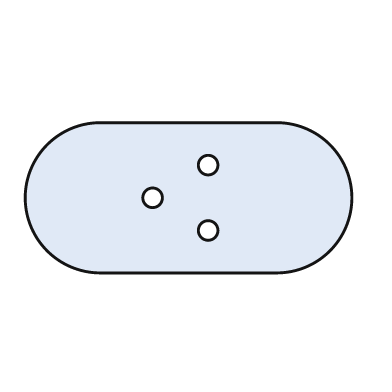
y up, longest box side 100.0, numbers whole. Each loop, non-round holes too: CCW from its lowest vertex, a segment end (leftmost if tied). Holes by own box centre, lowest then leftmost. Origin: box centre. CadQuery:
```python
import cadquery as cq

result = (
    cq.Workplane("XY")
    .moveTo(-27.0, -23.0)
    .lineTo(27.0, -23.0)
    .threePointArc((50.0, 0.0), (27.0, 23.0))
    .lineTo(-27.0, 23.0)
    .threePointArc((-50.0, 0.0), (-27.0, -23.0))
    .close()
    .moveTo(6.0, -10.0)
    .circle(3.0)
    .moveTo(-11.0, 0.0)
    .circle(3.0)
    .moveTo(6.0, 10.0)
    .circle(3.0)
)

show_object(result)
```